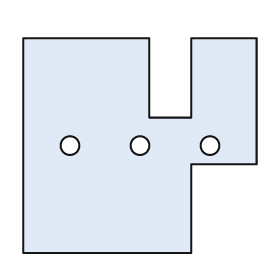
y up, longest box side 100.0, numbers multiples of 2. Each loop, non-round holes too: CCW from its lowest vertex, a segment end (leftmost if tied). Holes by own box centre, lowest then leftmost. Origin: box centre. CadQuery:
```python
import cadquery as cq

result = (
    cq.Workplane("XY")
    .moveTo(-50.0, -46.0)
    .lineTo(22.0, -46.0)
    .lineTo(22.0, -8.0)
    .lineTo(50.0, -8.0)
    .lineTo(50.0, 46.0)
    .lineTo(22.0, 46.0)
    .lineTo(22.0, 12.0)
    .lineTo(4.0, 12.0)
    .lineTo(4.0, 46.0)
    .lineTo(-50.0, 46.0)
    .close()
    .moveTo(-30.0, 0.0)
    .circle(4.0)
    .moveTo(0.0, 0.0)
    .circle(4.0)
    .moveTo(30.0, 0.0)
    .circle(4.0)
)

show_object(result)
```